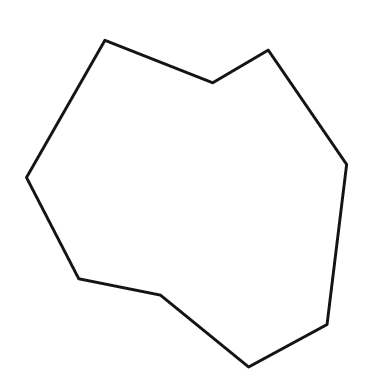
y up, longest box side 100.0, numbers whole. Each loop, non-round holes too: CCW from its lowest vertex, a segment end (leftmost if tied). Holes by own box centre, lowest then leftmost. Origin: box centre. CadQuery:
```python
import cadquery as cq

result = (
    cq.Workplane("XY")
    .moveTo(19.0, -50.0)
    .lineTo(43.0, -37.0)
    .lineTo(49.0, 12.0)
    .lineTo(25.0, 47.0)
    .lineTo(8.0, 37.0)
    .lineTo(-25.0, 50.0)
    .lineTo(-49.0, 8.0)
    .lineTo(-33.0, -23.0)
    .lineTo(-8.0, -28.0)
    .close()
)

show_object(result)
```